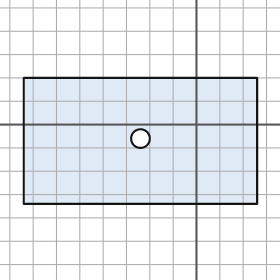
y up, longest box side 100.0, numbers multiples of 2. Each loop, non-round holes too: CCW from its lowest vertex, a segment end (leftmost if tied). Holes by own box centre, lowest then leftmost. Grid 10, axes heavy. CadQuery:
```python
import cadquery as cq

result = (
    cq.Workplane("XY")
    .moveTo(-74.0, -34.0)
    .lineTo(26.0, -34.0)
    .lineTo(26.0, 20.0)
    .lineTo(-74.0, 20.0)
    .close()
    .moveTo(-24.0, -6.0)
    .circle(4.0)
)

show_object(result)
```